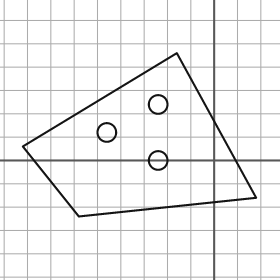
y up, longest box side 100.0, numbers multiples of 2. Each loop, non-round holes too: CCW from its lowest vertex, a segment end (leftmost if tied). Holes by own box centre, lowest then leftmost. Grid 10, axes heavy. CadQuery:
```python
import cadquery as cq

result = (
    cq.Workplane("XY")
    .moveTo(-58.0, -24.0)
    .lineTo(18.0, -16.0)
    .lineTo(-16.0, 46.0)
    .lineTo(-82.0, 6.0)
    .close()
    .moveTo(-24.0, 0.0)
    .circle(4.0)
    .moveTo(-46.0, 12.0)
    .circle(4.0)
    .moveTo(-24.0, 24.0)
    .circle(4.0)
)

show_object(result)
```